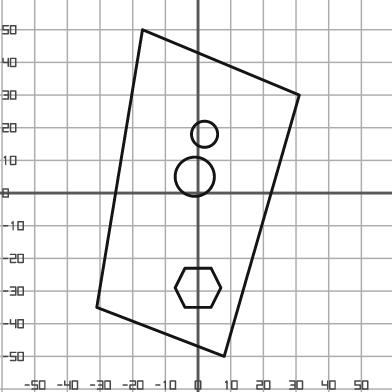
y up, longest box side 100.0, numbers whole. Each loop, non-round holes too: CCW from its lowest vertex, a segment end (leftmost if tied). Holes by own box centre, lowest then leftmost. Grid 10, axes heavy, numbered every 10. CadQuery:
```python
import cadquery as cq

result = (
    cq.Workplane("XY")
    .moveTo(8.0, -50.0)
    .lineTo(31.0, 30.0)
    .lineTo(-17.0, 50.0)
    .lineTo(-31.0, -35.0)
    .close()
    .moveTo(-4.0, -35.0)
    .lineTo(4.0, -35.0)
    .lineTo(7.0, -29.0)
    .lineTo(4.0, -23.0)
    .lineTo(-4.0, -23.0)
    .lineTo(-7.0, -29.0)
    .close()
    .moveTo(-1.0, 5.0)
    .circle(6.0)
    .moveTo(2.0, 18.0)
    .circle(4.0)
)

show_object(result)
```